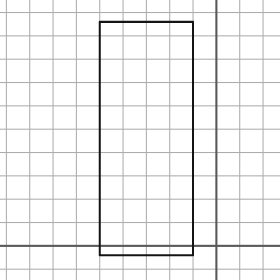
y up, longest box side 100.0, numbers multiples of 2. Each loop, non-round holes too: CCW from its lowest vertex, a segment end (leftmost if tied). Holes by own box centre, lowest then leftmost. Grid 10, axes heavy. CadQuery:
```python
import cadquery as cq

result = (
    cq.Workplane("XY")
    .moveTo(-50.0, -4.0)
    .lineTo(-10.0, -4.0)
    .lineTo(-10.0, 96.0)
    .lineTo(-50.0, 96.0)
    .close()
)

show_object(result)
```